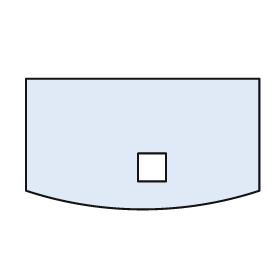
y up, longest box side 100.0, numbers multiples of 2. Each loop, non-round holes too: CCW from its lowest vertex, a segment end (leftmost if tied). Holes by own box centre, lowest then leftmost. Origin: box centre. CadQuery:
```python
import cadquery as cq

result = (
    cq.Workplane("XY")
    .moveTo(-50.0, -20.0)
    .threePointArc((0.0, -28.0), (50.0, -20.0))
    .lineTo(50.0, 28.0)
    .lineTo(-50.0, 28.0)
    .close()
    .moveTo(-2.0, -16.0)
    .lineTo(10.0, -16.0)
    .lineTo(10.0, -4.0)
    .lineTo(-2.0, -4.0)
    .close()
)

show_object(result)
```